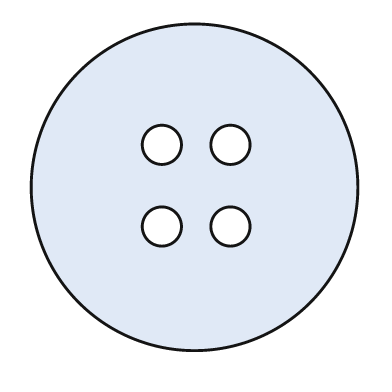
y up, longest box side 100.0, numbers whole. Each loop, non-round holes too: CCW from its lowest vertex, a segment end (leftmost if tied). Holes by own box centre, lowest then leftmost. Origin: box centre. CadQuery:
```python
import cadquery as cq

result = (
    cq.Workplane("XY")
    .moveTo(0.0, 0.0)
    .circle(50.0)
    .moveTo(-10.0, -12.0)
    .circle(6.0)
    .moveTo(11.0, -12.0)
    .circle(6.0)
    .moveTo(-10.0, 13.0)
    .circle(6.0)
    .moveTo(11.0, 13.0)
    .circle(6.0)
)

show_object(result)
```